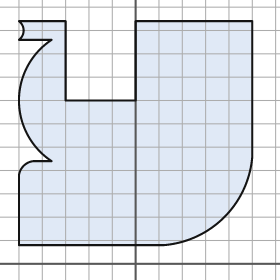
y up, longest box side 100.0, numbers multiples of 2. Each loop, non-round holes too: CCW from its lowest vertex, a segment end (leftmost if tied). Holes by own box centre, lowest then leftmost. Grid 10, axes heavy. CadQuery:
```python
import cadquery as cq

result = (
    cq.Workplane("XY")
    .moveTo(-50.0, 8.0)
    .lineTo(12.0, 8.0)
    .threePointArc((38.0, 20.0), (50.0, 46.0))
    .lineTo(50.0, 104.0)
    .lineTo(0.0, 104.0)
    .lineTo(0.0, 70.0)
    .lineTo(-30.0, 70.0)
    .lineTo(-30.0, 104.0)
    .lineTo(-50.0, 104.0)
    .threePointArc((-48.0, 100.0), (-50.0, 96.0))
    .lineTo(-36.0, 96.0)
    .threePointArc((-50.0, 70.0), (-36.0, 44.0))
    .lineTo(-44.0, 44.0)
    .threePointArc((-48.0, 42.0), (-50.0, 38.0))
    .close()
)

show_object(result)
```